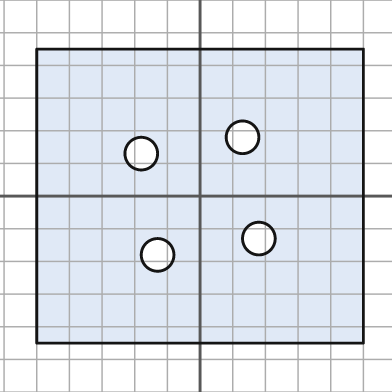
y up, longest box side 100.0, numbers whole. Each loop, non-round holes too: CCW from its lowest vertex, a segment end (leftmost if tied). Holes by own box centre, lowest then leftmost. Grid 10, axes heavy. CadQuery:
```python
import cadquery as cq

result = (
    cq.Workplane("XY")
    .moveTo(-50.0, -45.0)
    .lineTo(50.0, -45.0)
    .lineTo(50.0, 45.0)
    .lineTo(-50.0, 45.0)
    .close()
    .moveTo(-13.0, -18.0)
    .circle(5.0)
    .moveTo(18.0, -13.0)
    .circle(5.0)
    .moveTo(-18.0, 13.0)
    .circle(5.0)
    .moveTo(13.0, 18.0)
    .circle(5.0)
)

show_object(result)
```